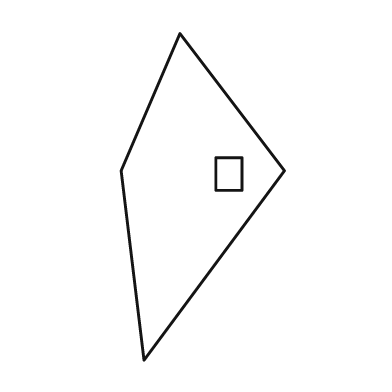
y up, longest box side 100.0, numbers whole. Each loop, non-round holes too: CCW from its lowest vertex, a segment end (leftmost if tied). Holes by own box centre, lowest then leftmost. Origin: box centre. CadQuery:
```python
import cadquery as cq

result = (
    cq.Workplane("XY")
    .moveTo(-18.0, -50.0)
    .lineTo(25.0, 8.0)
    .lineTo(-7.0, 50.0)
    .lineTo(-25.0, 8.0)
    .close()
    .moveTo(4.0, 2.0)
    .lineTo(12.0, 2.0)
    .lineTo(12.0, 12.0)
    .lineTo(4.0, 12.0)
    .close()
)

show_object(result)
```